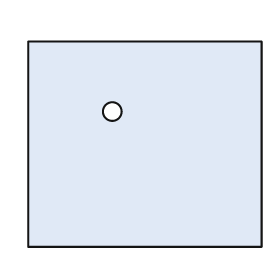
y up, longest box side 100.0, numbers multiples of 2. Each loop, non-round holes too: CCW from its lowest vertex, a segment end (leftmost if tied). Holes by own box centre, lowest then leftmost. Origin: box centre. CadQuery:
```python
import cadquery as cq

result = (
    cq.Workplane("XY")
    .moveTo(-50.0, -44.0)
    .lineTo(50.0, -44.0)
    .lineTo(50.0, 44.0)
    .lineTo(-50.0, 44.0)
    .close()
    .moveTo(-14.0, 14.0)
    .circle(4.0)
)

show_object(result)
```